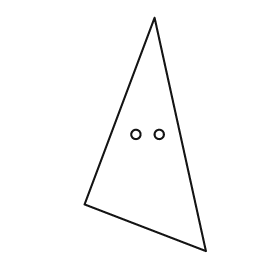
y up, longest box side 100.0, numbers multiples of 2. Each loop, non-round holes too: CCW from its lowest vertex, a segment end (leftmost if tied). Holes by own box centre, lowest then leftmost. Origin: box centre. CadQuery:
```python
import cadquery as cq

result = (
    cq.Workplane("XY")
    .moveTo(26.0, -50.0)
    .lineTo(4.0, 50.0)
    .lineTo(-26.0, -30.0)
    .close()
    .moveTo(-4.0, 0.0)
    .circle(2.0)
    .moveTo(6.0, 0.0)
    .circle(2.0)
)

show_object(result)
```